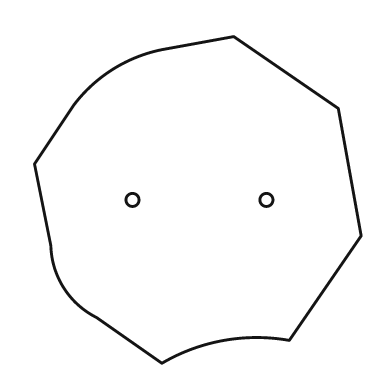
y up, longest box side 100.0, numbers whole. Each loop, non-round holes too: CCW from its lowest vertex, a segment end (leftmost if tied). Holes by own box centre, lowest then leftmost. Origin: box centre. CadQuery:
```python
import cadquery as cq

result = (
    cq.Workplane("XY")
    .moveTo(-11.0, -50.0)
    .threePointArc((8.0, -43.0), (28.0, -43.0))
    .lineTo(50.0, -11.0)
    .lineTo(43.0, 28.0)
    .lineTo(11.0, 50.0)
    .lineTo(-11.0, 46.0)
    .threePointArc((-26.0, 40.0), (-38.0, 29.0))
    .lineTo(-50.0, 11.0)
    .lineTo(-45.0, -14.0)
    .threePointArc((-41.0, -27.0), (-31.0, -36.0))
    .close()
    .moveTo(-20.0, 0.0)
    .circle(2.0)
    .moveTo(21.0, 0.0)
    .circle(2.0)
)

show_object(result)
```